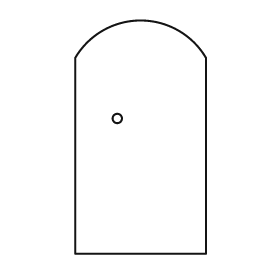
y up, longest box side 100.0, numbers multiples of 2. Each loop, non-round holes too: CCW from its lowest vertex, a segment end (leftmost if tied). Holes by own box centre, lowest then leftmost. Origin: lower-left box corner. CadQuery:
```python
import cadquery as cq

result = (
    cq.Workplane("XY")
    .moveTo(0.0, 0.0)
    .lineTo(56.0, 0.0)
    .lineTo(56.0, 84.0)
    .threePointArc((28.0, 100.0), (0.0, 84.0))
    .close()
    .moveTo(18.0, 58.0)
    .circle(2.0)
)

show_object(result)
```